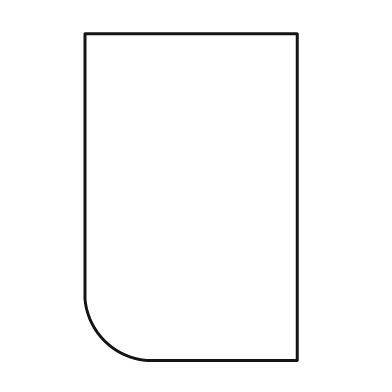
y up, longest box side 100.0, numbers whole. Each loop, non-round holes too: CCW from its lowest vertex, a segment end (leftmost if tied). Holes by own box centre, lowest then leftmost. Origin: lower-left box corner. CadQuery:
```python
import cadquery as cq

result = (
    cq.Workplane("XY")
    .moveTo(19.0, 0.0)
    .lineTo(65.0, 0.0)
    .lineTo(65.0, 100.0)
    .lineTo(0.0, 100.0)
    .lineTo(0.0, 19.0)
    .threePointArc((6.0, 6.0), (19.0, 0.0))
    .close()
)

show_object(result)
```